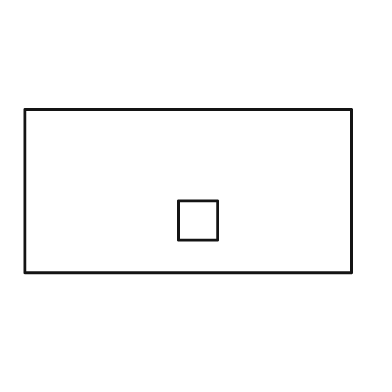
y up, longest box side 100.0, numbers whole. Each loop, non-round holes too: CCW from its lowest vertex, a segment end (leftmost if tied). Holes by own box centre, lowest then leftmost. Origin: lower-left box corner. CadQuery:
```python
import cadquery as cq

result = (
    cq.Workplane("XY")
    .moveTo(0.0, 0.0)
    .lineTo(100.0, 0.0)
    .lineTo(100.0, 50.0)
    .lineTo(0.0, 50.0)
    .close()
    .moveTo(47.0, 10.0)
    .lineTo(59.0, 10.0)
    .lineTo(59.0, 22.0)
    .lineTo(47.0, 22.0)
    .close()
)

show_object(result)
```